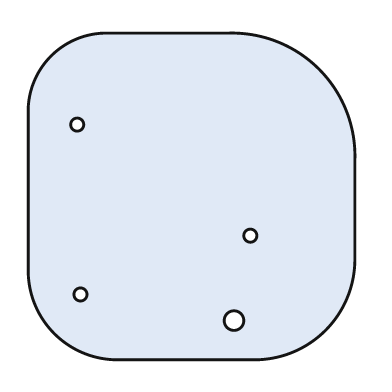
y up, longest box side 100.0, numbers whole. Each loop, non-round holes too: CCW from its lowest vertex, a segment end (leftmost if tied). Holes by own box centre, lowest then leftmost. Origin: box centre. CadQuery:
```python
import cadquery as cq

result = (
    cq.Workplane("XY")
    .moveTo(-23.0, -50.0)
    .lineTo(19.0, -50.0)
    .threePointArc((41.0, -41.0), (50.0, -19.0))
    .lineTo(50.0, 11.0)
    .threePointArc((39.0, 39.0), (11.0, 50.0))
    .lineTo(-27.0, 50.0)
    .threePointArc((-43.0, 43.0), (-50.0, 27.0))
    .lineTo(-50.0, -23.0)
    .threePointArc((-42.0, -42.0), (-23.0, -50.0))
    .close()
    .moveTo(13.0, -38.0)
    .circle(3.0)
    .moveTo(-34.0, -30.0)
    .circle(2.0)
    .moveTo(18.0, -12.0)
    .circle(2.0)
    .moveTo(-35.0, 22.0)
    .circle(2.0)
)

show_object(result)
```